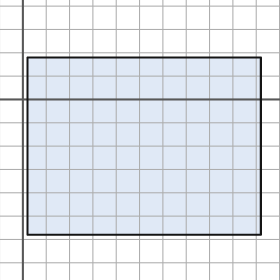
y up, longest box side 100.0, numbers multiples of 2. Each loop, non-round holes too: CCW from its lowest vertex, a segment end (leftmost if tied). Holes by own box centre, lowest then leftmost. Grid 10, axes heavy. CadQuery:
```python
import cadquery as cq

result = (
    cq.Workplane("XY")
    .moveTo(2.0, -58.0)
    .lineTo(102.0, -58.0)
    .lineTo(102.0, 18.0)
    .lineTo(2.0, 18.0)
    .close()
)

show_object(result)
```